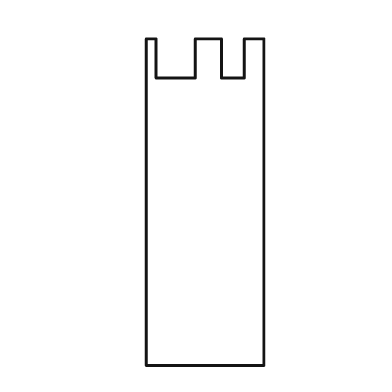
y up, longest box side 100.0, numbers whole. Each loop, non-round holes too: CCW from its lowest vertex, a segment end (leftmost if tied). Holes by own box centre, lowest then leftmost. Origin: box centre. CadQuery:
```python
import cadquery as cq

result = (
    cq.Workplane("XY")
    .moveTo(-18.0, -50.0)
    .lineTo(18.0, -50.0)
    .lineTo(18.0, 50.0)
    .lineTo(12.0, 50.0)
    .lineTo(12.0, 38.0)
    .lineTo(5.0, 38.0)
    .lineTo(5.0, 50.0)
    .lineTo(-3.0, 50.0)
    .lineTo(-3.0, 38.0)
    .lineTo(-15.0, 38.0)
    .lineTo(-15.0, 50.0)
    .lineTo(-18.0, 50.0)
    .close()
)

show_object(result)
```